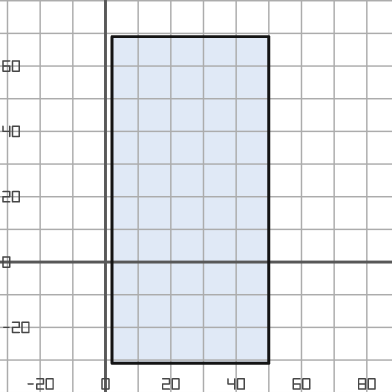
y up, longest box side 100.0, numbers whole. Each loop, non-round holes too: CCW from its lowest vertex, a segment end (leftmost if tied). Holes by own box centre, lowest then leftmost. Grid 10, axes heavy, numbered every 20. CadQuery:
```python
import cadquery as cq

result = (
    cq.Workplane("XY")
    .moveTo(2.0, -31.0)
    .lineTo(50.0, -31.0)
    .lineTo(50.0, 69.0)
    .lineTo(2.0, 69.0)
    .close()
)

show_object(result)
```